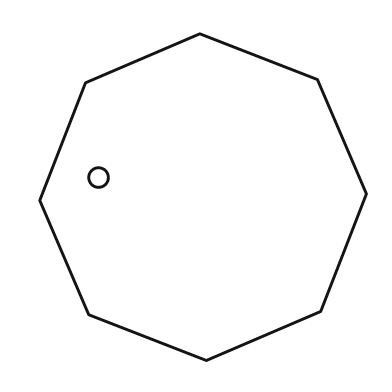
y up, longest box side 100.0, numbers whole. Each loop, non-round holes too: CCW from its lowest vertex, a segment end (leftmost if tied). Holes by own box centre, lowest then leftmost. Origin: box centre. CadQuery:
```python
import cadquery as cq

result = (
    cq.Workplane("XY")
    .moveTo(1.0, -50.0)
    .lineTo(36.0, -35.0)
    .lineTo(50.0, 1.0)
    .lineTo(35.0, 36.0)
    .lineTo(-1.0, 50.0)
    .lineTo(-36.0, 35.0)
    .lineTo(-50.0, -1.0)
    .lineTo(-35.0, -36.0)
    .close()
    .moveTo(-32.0, 6.0)
    .circle(3.0)
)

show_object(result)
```